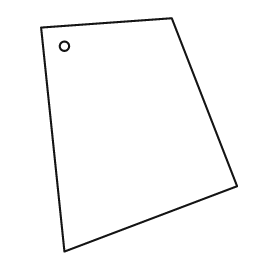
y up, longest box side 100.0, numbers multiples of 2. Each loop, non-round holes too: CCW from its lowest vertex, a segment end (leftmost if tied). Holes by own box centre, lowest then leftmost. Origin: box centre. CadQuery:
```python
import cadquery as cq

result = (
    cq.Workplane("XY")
    .moveTo(-32.0, -50.0)
    .lineTo(42.0, -22.0)
    .lineTo(14.0, 50.0)
    .lineTo(-42.0, 46.0)
    .close()
    .moveTo(-32.0, 38.0)
    .circle(2.0)
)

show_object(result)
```